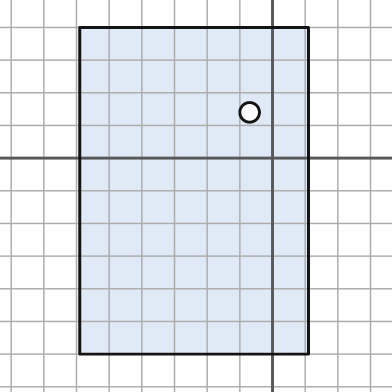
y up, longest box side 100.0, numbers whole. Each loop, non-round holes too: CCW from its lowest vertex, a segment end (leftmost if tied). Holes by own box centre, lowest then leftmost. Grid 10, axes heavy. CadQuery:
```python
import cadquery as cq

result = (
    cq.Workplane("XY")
    .moveTo(-59.0, -60.0)
    .lineTo(11.0, -60.0)
    .lineTo(11.0, 40.0)
    .lineTo(-59.0, 40.0)
    .close()
    .moveTo(-7.0, 14.0)
    .circle(3.0)
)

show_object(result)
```